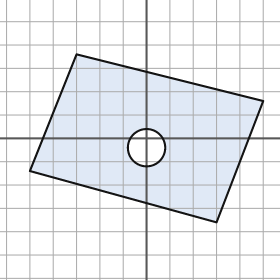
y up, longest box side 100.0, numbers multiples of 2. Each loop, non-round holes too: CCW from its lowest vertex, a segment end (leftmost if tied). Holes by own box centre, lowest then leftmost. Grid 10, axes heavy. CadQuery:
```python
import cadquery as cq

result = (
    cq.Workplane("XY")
    .moveTo(30.0, -36.0)
    .lineTo(50.0, 16.0)
    .lineTo(-30.0, 36.0)
    .lineTo(-50.0, -14.0)
    .close()
    .moveTo(0.0, -4.0)
    .circle(8.0)
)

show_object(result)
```